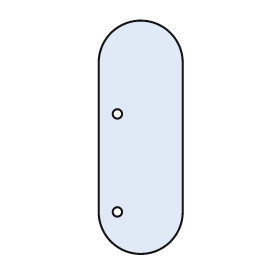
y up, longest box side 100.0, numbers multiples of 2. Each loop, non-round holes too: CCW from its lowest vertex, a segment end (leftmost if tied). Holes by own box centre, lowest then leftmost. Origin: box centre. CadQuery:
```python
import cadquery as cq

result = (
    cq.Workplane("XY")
    .moveTo(-18.0, -32.0)
    .threePointArc((0.0, -50.0), (18.0, -32.0))
    .lineTo(18.0, 32.0)
    .threePointArc((0.0, 50.0), (-18.0, 32.0))
    .close()
    .moveTo(-10.0, -32.0)
    .circle(2.0)
    .moveTo(-10.0, 10.0)
    .circle(2.0)
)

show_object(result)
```